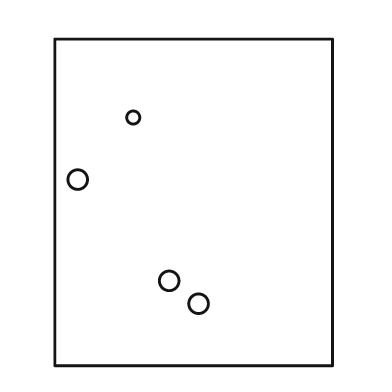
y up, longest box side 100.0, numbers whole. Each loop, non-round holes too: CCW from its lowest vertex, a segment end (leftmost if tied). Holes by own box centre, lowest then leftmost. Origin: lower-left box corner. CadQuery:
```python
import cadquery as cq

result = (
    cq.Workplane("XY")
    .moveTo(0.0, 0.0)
    .lineTo(85.0, 0.0)
    .lineTo(85.0, 100.0)
    .lineTo(0.0, 100.0)
    .close()
    .moveTo(44.0, 19.0)
    .circle(3.0)
    .moveTo(35.0, 26.0)
    .circle(3.0)
    .moveTo(7.0, 57.0)
    .circle(3.0)
    .moveTo(24.0, 76.0)
    .circle(2.0)
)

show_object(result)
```